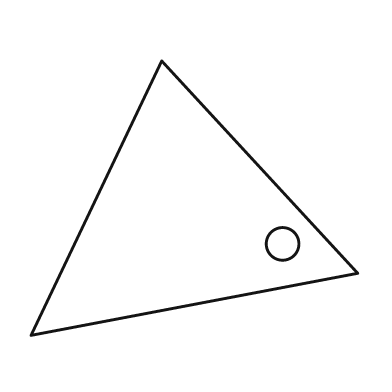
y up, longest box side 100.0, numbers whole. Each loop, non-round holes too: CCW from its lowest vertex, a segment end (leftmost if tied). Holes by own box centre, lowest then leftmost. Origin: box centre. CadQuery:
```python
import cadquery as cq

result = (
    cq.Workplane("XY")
    .moveTo(-50.0, -42.0)
    .lineTo(50.0, -23.0)
    .lineTo(-10.0, 42.0)
    .close()
    .moveTo(27.0, -14.0)
    .circle(5.0)
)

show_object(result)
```